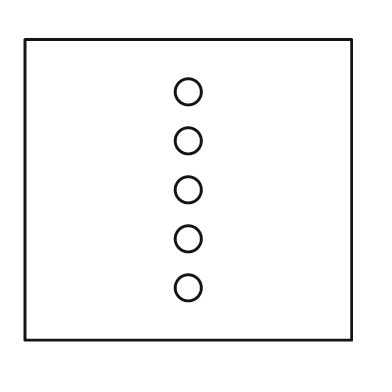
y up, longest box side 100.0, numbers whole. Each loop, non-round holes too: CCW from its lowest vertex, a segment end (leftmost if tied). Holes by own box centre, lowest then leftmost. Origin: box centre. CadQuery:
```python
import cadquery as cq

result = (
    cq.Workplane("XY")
    .moveTo(-50.0, -46.0)
    .lineTo(50.0, -46.0)
    .lineTo(50.0, 46.0)
    .lineTo(-50.0, 46.0)
    .close()
    .moveTo(0.0, -30.0)
    .circle(4.0)
    .moveTo(0.0, -15.0)
    .circle(4.0)
    .moveTo(0.0, 0.0)
    .circle(4.0)
    .moveTo(0.0, 15.0)
    .circle(4.0)
    .moveTo(0.0, 30.0)
    .circle(4.0)
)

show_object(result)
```